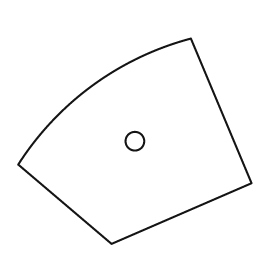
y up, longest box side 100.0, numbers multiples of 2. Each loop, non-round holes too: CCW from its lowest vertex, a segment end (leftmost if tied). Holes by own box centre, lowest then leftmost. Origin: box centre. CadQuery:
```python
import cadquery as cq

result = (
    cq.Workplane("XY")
    .moveTo(-10.0, -44.0)
    .lineTo(50.0, -18.0)
    .lineTo(24.0, 44.0)
    .threePointArc((-18.0, 24.0), (-50.0, -10.0))
    .close()
    .moveTo(0.0, 0.0)
    .circle(4.0)
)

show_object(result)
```